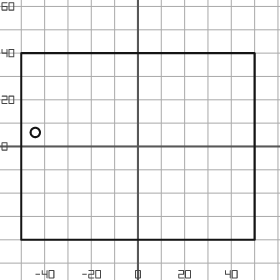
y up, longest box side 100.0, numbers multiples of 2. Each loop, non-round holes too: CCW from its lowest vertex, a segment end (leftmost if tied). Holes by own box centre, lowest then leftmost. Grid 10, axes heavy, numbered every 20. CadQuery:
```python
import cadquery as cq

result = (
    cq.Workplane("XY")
    .moveTo(-50.0, -40.0)
    .lineTo(50.0, -40.0)
    .lineTo(50.0, 40.0)
    .lineTo(-50.0, 40.0)
    .close()
    .moveTo(-44.0, 6.0)
    .circle(2.0)
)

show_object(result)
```